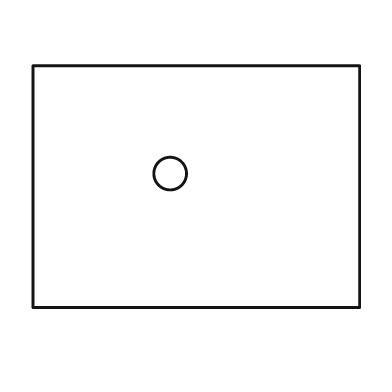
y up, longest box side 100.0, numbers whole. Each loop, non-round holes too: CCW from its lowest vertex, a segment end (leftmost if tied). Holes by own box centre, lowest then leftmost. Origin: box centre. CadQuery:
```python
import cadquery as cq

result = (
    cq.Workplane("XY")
    .moveTo(-50.0, -37.0)
    .lineTo(50.0, -37.0)
    .lineTo(50.0, 37.0)
    .lineTo(-50.0, 37.0)
    .close()
    .moveTo(-8.0, 4.0)
    .circle(5.0)
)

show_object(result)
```